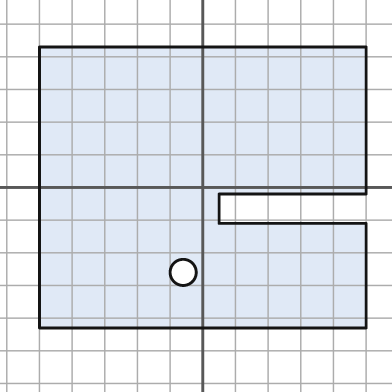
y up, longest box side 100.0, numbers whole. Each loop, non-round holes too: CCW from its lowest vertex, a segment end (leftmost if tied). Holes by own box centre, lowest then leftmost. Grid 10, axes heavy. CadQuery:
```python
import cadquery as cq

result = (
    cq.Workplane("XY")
    .moveTo(-50.0, -43.0)
    .lineTo(50.0, -43.0)
    .lineTo(50.0, -11.0)
    .lineTo(5.0, -11.0)
    .lineTo(5.0, -2.0)
    .lineTo(50.0, -2.0)
    .lineTo(50.0, 43.0)
    .lineTo(-50.0, 43.0)
    .close()
    .moveTo(-6.0, -26.0)
    .circle(4.0)
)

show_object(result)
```